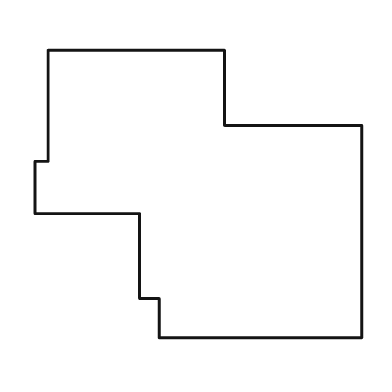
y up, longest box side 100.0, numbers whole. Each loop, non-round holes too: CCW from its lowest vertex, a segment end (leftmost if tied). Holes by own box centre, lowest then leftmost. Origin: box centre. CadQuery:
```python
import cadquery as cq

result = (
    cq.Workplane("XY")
    .moveTo(-12.0, -44.0)
    .lineTo(50.0, -44.0)
    .lineTo(50.0, 21.0)
    .lineTo(8.0, 21.0)
    .lineTo(8.0, 44.0)
    .lineTo(-46.0, 44.0)
    .lineTo(-46.0, 10.0)
    .lineTo(-50.0, 10.0)
    .lineTo(-50.0, -6.0)
    .lineTo(-18.0, -6.0)
    .lineTo(-18.0, -32.0)
    .lineTo(-12.0, -32.0)
    .close()
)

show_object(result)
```